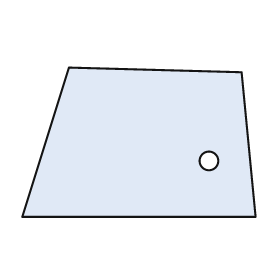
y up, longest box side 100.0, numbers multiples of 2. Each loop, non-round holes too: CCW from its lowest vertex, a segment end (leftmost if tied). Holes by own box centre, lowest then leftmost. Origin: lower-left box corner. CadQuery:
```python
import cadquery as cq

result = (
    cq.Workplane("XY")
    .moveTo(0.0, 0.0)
    .lineTo(100.0, 0.0)
    .lineTo(94.0, 62.0)
    .lineTo(20.0, 64.0)
    .close()
    .moveTo(80.0, 24.0)
    .circle(4.0)
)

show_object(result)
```